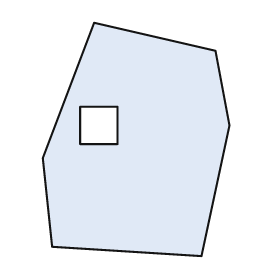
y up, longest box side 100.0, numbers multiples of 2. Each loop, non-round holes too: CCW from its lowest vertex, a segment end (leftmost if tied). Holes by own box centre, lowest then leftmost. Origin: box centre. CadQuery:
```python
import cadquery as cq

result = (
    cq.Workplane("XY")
    .moveTo(28.0, -50.0)
    .lineTo(40.0, 6.0)
    .lineTo(34.0, 38.0)
    .lineTo(-18.0, 50.0)
    .lineTo(-40.0, -8.0)
    .lineTo(-36.0, -46.0)
    .close()
    .moveTo(-24.0, -2.0)
    .lineTo(-8.0, -2.0)
    .lineTo(-8.0, 14.0)
    .lineTo(-24.0, 14.0)
    .close()
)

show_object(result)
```